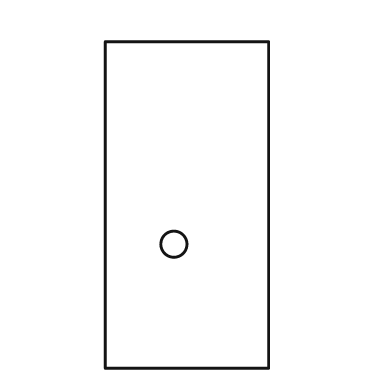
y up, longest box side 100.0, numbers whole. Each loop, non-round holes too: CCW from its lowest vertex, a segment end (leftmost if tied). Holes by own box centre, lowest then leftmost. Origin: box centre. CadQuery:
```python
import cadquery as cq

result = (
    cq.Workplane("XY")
    .moveTo(-25.0, -50.0)
    .lineTo(25.0, -50.0)
    .lineTo(25.0, 50.0)
    .lineTo(-25.0, 50.0)
    .close()
    .moveTo(-4.0, -12.0)
    .circle(4.0)
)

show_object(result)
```